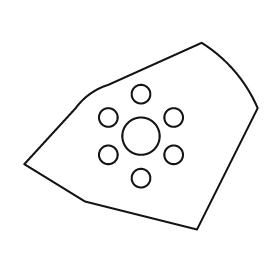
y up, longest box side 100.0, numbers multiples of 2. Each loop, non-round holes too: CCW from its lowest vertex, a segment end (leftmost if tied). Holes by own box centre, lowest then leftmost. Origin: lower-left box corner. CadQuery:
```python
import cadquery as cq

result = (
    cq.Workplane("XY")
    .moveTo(74.0, 0.0)
    .lineTo(100.0, 52.0)
    .threePointArc((90.0, 68.0), (76.0, 80.0))
    .lineTo(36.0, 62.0)
    .threePointArc((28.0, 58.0), (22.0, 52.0))
    .lineTo(0.0, 28.0)
    .lineTo(26.0, 12.0)
    .close()
    .moveTo(50.0, 22.0)
    .circle(4.0)
    .moveTo(36.0, 32.0)
    .circle(4.0)
    .moveTo(64.0, 32.0)
    .circle(4.0)
    .moveTo(50.0, 40.0)
    .circle(8.0)
    .moveTo(36.0, 48.0)
    .circle(4.0)
    .moveTo(64.0, 48.0)
    .circle(4.0)
    .moveTo(50.0, 58.0)
    .circle(4.0)
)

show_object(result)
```